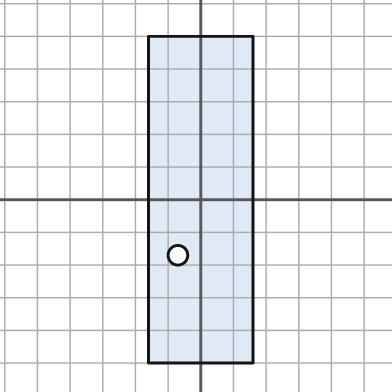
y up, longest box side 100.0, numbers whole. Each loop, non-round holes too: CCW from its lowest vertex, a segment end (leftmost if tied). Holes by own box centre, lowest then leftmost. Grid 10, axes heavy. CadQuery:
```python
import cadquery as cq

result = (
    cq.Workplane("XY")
    .moveTo(-16.0, -50.0)
    .lineTo(16.0, -50.0)
    .lineTo(16.0, 50.0)
    .lineTo(-16.0, 50.0)
    .close()
    .moveTo(-7.0, -17.0)
    .circle(3.0)
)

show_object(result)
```